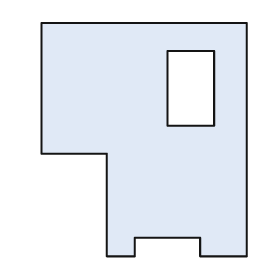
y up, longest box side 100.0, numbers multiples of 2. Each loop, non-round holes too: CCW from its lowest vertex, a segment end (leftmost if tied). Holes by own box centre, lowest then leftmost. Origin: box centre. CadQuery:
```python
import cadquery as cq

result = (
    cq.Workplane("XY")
    .moveTo(-16.0, -50.0)
    .lineTo(-4.0, -50.0)
    .lineTo(-4.0, -42.0)
    .lineTo(24.0, -42.0)
    .lineTo(24.0, -50.0)
    .lineTo(44.0, -50.0)
    .lineTo(44.0, 50.0)
    .lineTo(-44.0, 50.0)
    .lineTo(-44.0, -6.0)
    .lineTo(-16.0, -6.0)
    .close()
    .moveTo(10.0, 6.0)
    .lineTo(30.0, 6.0)
    .lineTo(30.0, 38.0)
    .lineTo(10.0, 38.0)
    .close()
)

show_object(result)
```